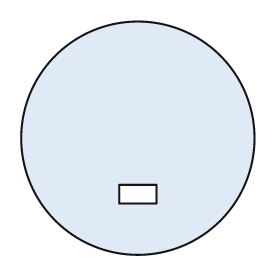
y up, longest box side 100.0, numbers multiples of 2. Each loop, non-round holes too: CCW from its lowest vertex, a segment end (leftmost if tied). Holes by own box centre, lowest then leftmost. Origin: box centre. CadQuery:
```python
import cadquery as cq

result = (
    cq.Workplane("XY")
    .moveTo(0.0, 0.0)
    .circle(50.0)
    .moveTo(-8.0, -28.0)
    .lineTo(8.0, -28.0)
    .lineTo(8.0, -20.0)
    .lineTo(-8.0, -20.0)
    .close()
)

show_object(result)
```